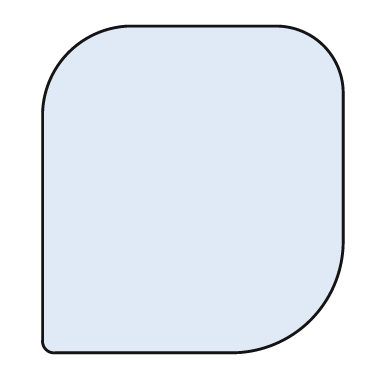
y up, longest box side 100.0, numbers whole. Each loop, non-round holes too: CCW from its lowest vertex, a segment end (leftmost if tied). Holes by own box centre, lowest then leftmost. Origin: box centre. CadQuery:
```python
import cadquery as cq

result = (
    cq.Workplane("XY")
    .moveTo(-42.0, -50.0)
    .lineTo(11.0, -50.0)
    .threePointArc((36.0, -40.0), (46.0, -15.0))
    .lineTo(46.0, 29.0)
    .threePointArc((40.0, 44.0), (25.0, 50.0))
    .lineTo(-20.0, 50.0)
    .threePointArc((-38.0, 42.0), (-46.0, 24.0))
    .lineTo(-46.0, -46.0)
    .threePointArc((-45.0, -49.0), (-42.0, -50.0))
    .close()
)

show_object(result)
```